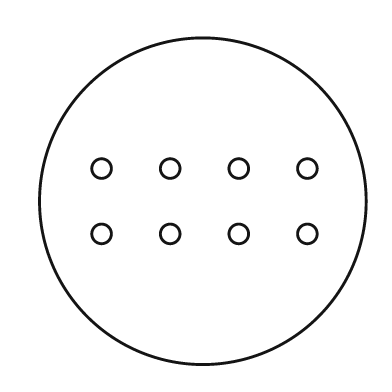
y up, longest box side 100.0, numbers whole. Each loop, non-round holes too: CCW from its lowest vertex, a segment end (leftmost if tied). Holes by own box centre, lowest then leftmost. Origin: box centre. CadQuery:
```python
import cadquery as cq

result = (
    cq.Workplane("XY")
    .moveTo(0.0, 0.0)
    .circle(50.0)
    .moveTo(-31.0, -10.0)
    .circle(3.0)
    .moveTo(-10.0, -10.0)
    .circle(3.0)
    .moveTo(11.0, -10.0)
    .circle(3.0)
    .moveTo(32.0, -10.0)
    .circle(3.0)
    .moveTo(-31.0, 10.0)
    .circle(3.0)
    .moveTo(-10.0, 10.0)
    .circle(3.0)
    .moveTo(11.0, 10.0)
    .circle(3.0)
    .moveTo(32.0, 10.0)
    .circle(3.0)
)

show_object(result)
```